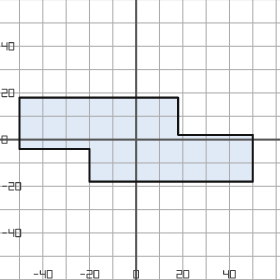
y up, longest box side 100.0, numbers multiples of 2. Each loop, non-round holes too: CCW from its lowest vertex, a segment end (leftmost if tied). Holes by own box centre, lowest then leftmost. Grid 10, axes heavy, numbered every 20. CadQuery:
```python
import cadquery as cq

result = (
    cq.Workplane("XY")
    .moveTo(-20.0, -18.0)
    .lineTo(50.0, -18.0)
    .lineTo(50.0, 2.0)
    .lineTo(18.0, 2.0)
    .lineTo(18.0, 18.0)
    .lineTo(-50.0, 18.0)
    .lineTo(-50.0, -4.0)
    .lineTo(-20.0, -4.0)
    .close()
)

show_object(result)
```